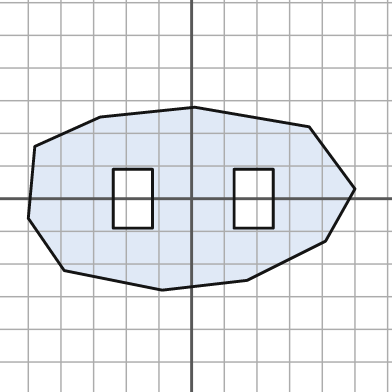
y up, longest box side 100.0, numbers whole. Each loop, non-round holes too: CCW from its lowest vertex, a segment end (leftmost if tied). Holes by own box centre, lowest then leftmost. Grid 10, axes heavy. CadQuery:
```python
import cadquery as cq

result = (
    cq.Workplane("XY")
    .moveTo(-9.0, -28.0)
    .lineTo(17.0, -25.0)
    .lineTo(41.0, -13.0)
    .lineTo(50.0, 3.0)
    .lineTo(36.0, 22.0)
    .lineTo(1.0, 28.0)
    .lineTo(-28.0, 25.0)
    .lineTo(-48.0, 16.0)
    .lineTo(-50.0, -6.0)
    .lineTo(-39.0, -22.0)
    .close()
    .moveTo(-24.0, -9.0)
    .lineTo(-12.0, -9.0)
    .lineTo(-12.0, 9.0)
    .lineTo(-24.0, 9.0)
    .close()
    .moveTo(13.0, -9.0)
    .lineTo(25.0, -9.0)
    .lineTo(25.0, 9.0)
    .lineTo(13.0, 9.0)
    .close()
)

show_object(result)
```